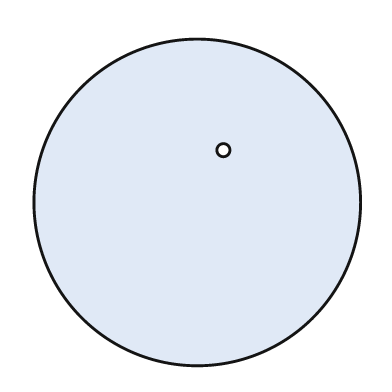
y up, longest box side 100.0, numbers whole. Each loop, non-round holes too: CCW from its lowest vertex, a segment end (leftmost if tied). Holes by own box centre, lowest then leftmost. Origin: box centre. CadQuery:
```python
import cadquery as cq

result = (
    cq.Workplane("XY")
    .moveTo(0.0, 0.0)
    .circle(50.0)
    .moveTo(8.0, 16.0)
    .circle(2.0)
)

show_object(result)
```